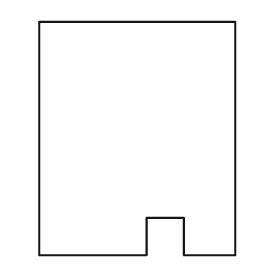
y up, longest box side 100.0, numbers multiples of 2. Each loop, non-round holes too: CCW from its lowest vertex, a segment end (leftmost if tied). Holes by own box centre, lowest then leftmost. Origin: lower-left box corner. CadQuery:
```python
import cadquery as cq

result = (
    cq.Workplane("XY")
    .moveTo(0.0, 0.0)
    .lineTo(46.0, 0.0)
    .lineTo(46.0, 16.0)
    .lineTo(62.0, 16.0)
    .lineTo(62.0, 0.0)
    .lineTo(84.0, 0.0)
    .lineTo(84.0, 100.0)
    .lineTo(0.0, 100.0)
    .close()
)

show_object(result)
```